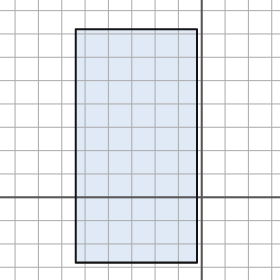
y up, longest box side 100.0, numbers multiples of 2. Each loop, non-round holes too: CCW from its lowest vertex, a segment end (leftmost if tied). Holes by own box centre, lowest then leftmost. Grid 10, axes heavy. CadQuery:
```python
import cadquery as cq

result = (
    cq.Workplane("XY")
    .moveTo(-54.0, -28.0)
    .lineTo(-2.0, -28.0)
    .lineTo(-2.0, 72.0)
    .lineTo(-54.0, 72.0)
    .close()
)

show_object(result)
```